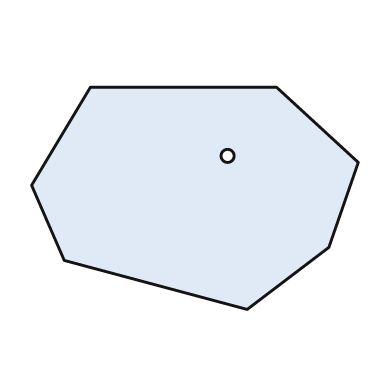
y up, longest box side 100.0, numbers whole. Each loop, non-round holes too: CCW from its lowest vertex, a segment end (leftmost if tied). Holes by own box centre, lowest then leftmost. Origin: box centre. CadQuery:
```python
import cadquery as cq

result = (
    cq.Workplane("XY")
    .moveTo(16.0, -34.0)
    .lineTo(41.0, -15.0)
    .lineTo(50.0, 11.0)
    .lineTo(25.0, 34.0)
    .lineTo(-32.0, 34.0)
    .lineTo(-50.0, 4.0)
    .lineTo(-40.0, -19.0)
    .close()
    .moveTo(10.0, 13.0)
    .circle(2.0)
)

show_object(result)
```